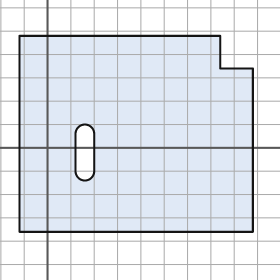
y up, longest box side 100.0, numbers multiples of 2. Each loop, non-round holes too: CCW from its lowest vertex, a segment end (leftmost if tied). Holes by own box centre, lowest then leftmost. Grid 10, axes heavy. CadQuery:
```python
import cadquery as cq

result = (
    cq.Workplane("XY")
    .moveTo(-12.0, -36.0)
    .lineTo(88.0, -36.0)
    .lineTo(88.0, 34.0)
    .lineTo(74.0, 34.0)
    .lineTo(74.0, 48.0)
    .lineTo(-12.0, 48.0)
    .close()
    .moveTo(12.0, -10.0)
    .threePointArc((16.0, -14.0), (20.0, -10.0))
    .lineTo(20.0, 6.0)
    .threePointArc((16.0, 10.0), (12.0, 6.0))
    .close()
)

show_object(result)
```